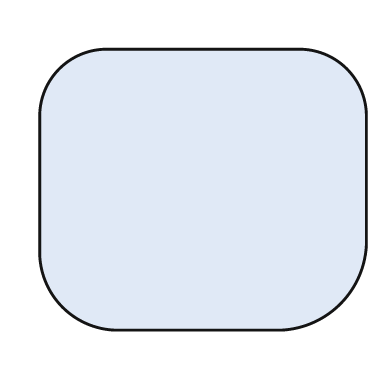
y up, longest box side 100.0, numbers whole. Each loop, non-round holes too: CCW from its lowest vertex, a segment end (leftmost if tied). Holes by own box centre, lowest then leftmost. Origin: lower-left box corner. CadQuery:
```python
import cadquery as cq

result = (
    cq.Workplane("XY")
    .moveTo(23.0, 0.0)
    .lineTo(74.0, 0.0)
    .threePointArc((92.0, 8.0), (100.0, 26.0))
    .lineTo(100.0, 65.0)
    .threePointArc((94.0, 80.0), (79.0, 86.0))
    .lineTo(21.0, 86.0)
    .threePointArc((6.0, 80.0), (0.0, 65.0))
    .lineTo(0.0, 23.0)
    .threePointArc((7.0, 7.0), (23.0, 0.0))
    .close()
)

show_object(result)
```